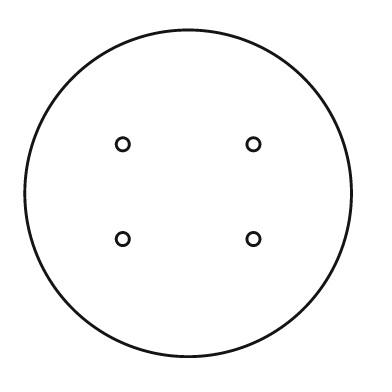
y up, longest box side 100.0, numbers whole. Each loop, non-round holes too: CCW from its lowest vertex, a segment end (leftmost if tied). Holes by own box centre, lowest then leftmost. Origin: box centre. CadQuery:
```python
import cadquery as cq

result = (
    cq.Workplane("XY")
    .moveTo(0.0, 0.0)
    .circle(50.0)
    .moveTo(-20.0, -14.0)
    .circle(2.0)
    .moveTo(20.0, -14.0)
    .circle(2.0)
    .moveTo(-20.0, 15.0)
    .circle(2.0)
    .moveTo(20.0, 15.0)
    .circle(2.0)
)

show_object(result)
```